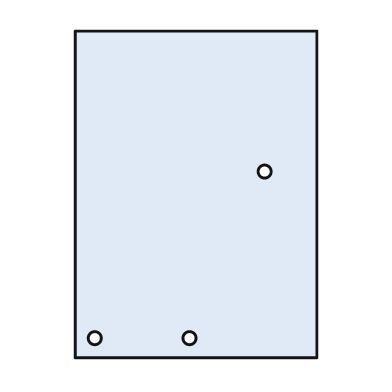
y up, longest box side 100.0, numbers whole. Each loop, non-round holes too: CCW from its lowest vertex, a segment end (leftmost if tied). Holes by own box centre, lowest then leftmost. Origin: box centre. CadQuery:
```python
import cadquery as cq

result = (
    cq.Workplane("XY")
    .moveTo(-37.0, -50.0)
    .lineTo(37.0, -50.0)
    .lineTo(37.0, 50.0)
    .lineTo(-37.0, 50.0)
    .close()
    .moveTo(-31.0, -44.0)
    .circle(2.0)
    .moveTo(-2.0, -44.0)
    .circle(2.0)
    .moveTo(21.0, 7.0)
    .circle(2.0)
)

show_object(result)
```